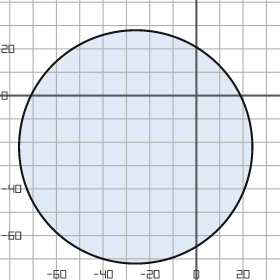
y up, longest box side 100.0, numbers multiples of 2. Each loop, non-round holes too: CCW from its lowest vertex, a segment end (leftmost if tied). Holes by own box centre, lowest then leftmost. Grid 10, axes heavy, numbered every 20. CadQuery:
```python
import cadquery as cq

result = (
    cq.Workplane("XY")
    .moveTo(-26.0, -22.0)
    .circle(50.0)
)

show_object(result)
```